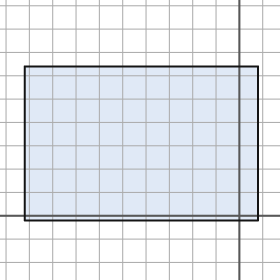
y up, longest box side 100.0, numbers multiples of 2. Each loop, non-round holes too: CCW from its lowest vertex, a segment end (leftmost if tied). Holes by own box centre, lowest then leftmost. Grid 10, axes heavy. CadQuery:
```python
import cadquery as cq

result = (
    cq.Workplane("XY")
    .moveTo(-92.0, -2.0)
    .lineTo(8.0, -2.0)
    .lineTo(8.0, 64.0)
    .lineTo(-92.0, 64.0)
    .close()
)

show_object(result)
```